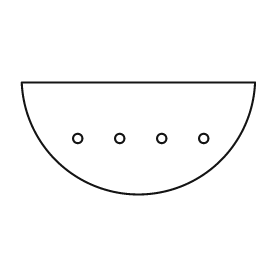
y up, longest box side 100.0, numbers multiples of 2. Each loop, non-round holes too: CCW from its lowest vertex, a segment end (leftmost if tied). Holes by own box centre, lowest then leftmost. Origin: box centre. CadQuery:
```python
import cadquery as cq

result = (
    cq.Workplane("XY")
    .moveTo(-50.0, 24.0)
    .threePointArc((0.0, -24.0), (50.0, 24.0))
    .close()
    .moveTo(-26.0, 0.0)
    .circle(2.0)
    .moveTo(-8.0, 0.0)
    .circle(2.0)
    .moveTo(10.0, 0.0)
    .circle(2.0)
    .moveTo(28.0, 0.0)
    .circle(2.0)
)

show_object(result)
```